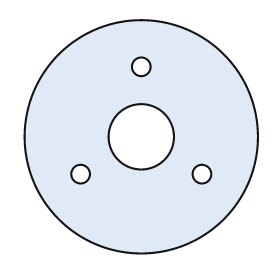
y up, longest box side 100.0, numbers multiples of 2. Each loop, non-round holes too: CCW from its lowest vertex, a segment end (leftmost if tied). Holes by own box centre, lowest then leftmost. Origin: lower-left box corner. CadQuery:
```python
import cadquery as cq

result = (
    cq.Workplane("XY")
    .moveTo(50.0, 50.0)
    .circle(50.0)
    .moveTo(24.0, 34.0)
    .circle(4.0)
    .moveTo(76.0, 34.0)
    .circle(4.0)
    .moveTo(50.0, 50.0)
    .circle(14.0)
    .moveTo(50.0, 80.0)
    .circle(4.0)
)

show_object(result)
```